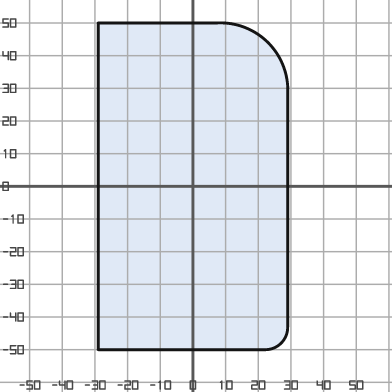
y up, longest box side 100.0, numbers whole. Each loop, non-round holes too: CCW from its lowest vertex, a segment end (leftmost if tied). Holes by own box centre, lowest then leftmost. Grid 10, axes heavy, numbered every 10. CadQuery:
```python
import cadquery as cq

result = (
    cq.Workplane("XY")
    .moveTo(-29.0, -50.0)
    .lineTo(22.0, -50.0)
    .threePointArc((27.0, -48.0), (29.0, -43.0))
    .lineTo(29.0, 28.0)
    .threePointArc((23.0, 44.0), (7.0, 50.0))
    .lineTo(-29.0, 50.0)
    .close()
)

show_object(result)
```